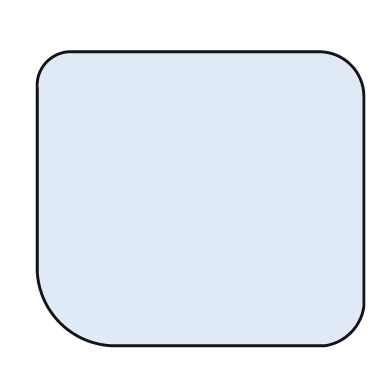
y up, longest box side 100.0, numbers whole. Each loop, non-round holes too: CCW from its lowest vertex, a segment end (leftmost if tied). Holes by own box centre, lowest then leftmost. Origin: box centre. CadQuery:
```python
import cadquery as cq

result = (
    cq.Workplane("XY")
    .moveTo(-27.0, -45.0)
    .lineTo(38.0, -45.0)
    .threePointArc((46.0, -41.0), (50.0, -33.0))
    .lineTo(50.0, 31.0)
    .threePointArc((46.0, 41.0), (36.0, 45.0))
    .lineTo(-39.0, 45.0)
    .threePointArc((-47.0, 42.0), (-50.0, 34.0))
    .lineTo(-50.0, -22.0)
    .threePointArc((-43.0, -38.0), (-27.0, -45.0))
    .close()
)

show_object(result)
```